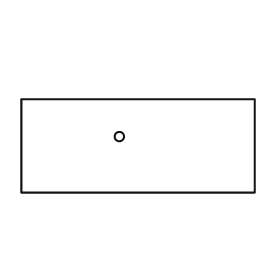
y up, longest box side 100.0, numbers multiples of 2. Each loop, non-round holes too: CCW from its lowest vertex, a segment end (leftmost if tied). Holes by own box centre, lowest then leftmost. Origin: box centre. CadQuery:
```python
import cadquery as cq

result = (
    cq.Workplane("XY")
    .moveTo(-50.0, -20.0)
    .lineTo(50.0, -20.0)
    .lineTo(50.0, 20.0)
    .lineTo(-50.0, 20.0)
    .close()
    .moveTo(-8.0, 4.0)
    .circle(2.0)
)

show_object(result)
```